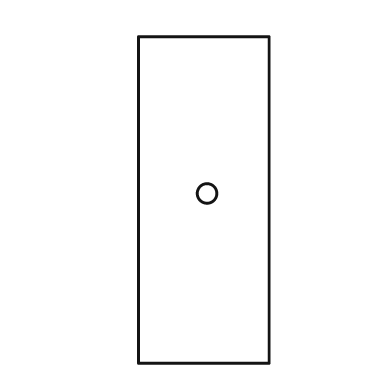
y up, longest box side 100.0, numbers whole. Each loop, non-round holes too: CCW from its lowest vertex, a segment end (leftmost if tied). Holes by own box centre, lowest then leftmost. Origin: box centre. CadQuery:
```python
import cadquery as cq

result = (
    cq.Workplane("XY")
    .moveTo(-20.0, -50.0)
    .lineTo(20.0, -50.0)
    .lineTo(20.0, 50.0)
    .lineTo(-20.0, 50.0)
    .close()
    .moveTo(1.0, 2.0)
    .circle(3.0)
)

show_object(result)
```